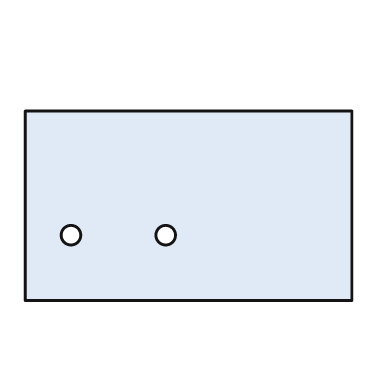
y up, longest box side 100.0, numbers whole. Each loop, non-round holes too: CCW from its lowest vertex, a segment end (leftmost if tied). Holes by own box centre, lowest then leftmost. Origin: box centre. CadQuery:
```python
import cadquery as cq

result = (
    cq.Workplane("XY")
    .moveTo(-50.0, -29.0)
    .lineTo(50.0, -29.0)
    .lineTo(50.0, 29.0)
    .lineTo(-50.0, 29.0)
    .close()
    .moveTo(-36.0, -9.0)
    .circle(3.0)
    .moveTo(-7.0, -9.0)
    .circle(3.0)
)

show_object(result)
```